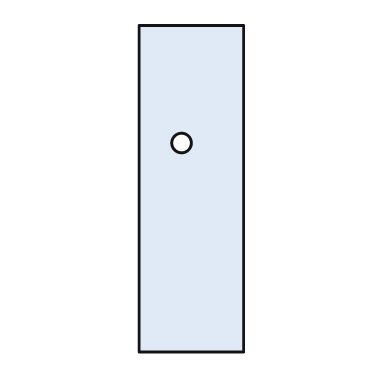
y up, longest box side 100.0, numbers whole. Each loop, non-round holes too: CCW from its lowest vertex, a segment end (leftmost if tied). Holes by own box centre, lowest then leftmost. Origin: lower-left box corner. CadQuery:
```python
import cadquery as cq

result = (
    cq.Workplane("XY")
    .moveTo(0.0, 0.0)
    .lineTo(32.0, 0.0)
    .lineTo(32.0, 100.0)
    .lineTo(0.0, 100.0)
    .close()
    .moveTo(13.0, 64.0)
    .circle(3.0)
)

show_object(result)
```